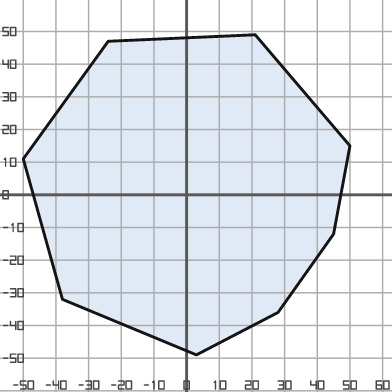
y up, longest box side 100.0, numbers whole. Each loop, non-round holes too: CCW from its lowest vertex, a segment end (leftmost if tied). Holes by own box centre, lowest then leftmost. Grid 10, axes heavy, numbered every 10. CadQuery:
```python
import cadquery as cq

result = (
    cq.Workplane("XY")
    .moveTo(3.0, -49.0)
    .lineTo(28.0, -36.0)
    .lineTo(45.0, -12.0)
    .lineTo(50.0, 15.0)
    .lineTo(21.0, 49.0)
    .lineTo(-24.0, 47.0)
    .lineTo(-50.0, 11.0)
    .lineTo(-38.0, -32.0)
    .close()
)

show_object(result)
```